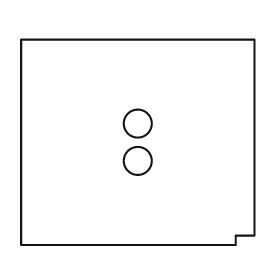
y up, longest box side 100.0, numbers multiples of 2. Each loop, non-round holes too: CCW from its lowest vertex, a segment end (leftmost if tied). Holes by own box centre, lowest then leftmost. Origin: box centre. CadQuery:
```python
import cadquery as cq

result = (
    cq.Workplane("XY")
    .moveTo(-50.0, -44.0)
    .lineTo(42.0, -44.0)
    .lineTo(42.0, -40.0)
    .lineTo(50.0, -40.0)
    .lineTo(50.0, 44.0)
    .lineTo(-50.0, 44.0)
    .close()
    .moveTo(0.0, -8.0)
    .circle(6.0)
    .moveTo(0.0, 8.0)
    .circle(6.0)
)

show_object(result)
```